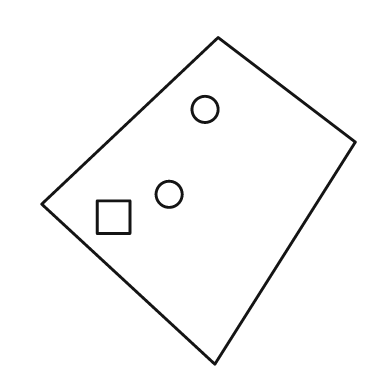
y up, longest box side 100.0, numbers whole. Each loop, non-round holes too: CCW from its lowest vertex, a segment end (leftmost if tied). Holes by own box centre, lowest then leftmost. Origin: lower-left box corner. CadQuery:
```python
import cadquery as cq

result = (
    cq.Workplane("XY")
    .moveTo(53.0, 0.0)
    .lineTo(96.0, 68.0)
    .lineTo(54.0, 100.0)
    .lineTo(0.0, 49.0)
    .close()
    .moveTo(17.0, 40.0)
    .lineTo(27.0, 40.0)
    .lineTo(27.0, 50.0)
    .lineTo(17.0, 50.0)
    .close()
    .moveTo(39.0, 52.0)
    .circle(4.0)
    .moveTo(50.0, 78.0)
    .circle(4.0)
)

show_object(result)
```